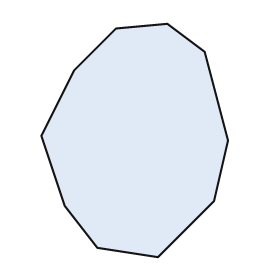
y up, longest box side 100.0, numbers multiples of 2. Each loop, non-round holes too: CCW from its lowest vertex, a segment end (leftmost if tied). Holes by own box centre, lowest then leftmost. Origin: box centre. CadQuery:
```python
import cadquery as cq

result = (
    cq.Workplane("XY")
    .moveTo(10.0, -50.0)
    .lineTo(34.0, -26.0)
    .lineTo(40.0, 0.0)
    .lineTo(30.0, 38.0)
    .lineTo(14.0, 50.0)
    .lineTo(-8.0, 48.0)
    .lineTo(-26.0, 30.0)
    .lineTo(-40.0, 2.0)
    .lineTo(-30.0, -28.0)
    .lineTo(-16.0, -46.0)
    .close()
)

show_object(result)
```